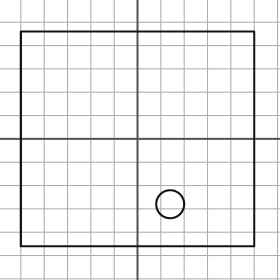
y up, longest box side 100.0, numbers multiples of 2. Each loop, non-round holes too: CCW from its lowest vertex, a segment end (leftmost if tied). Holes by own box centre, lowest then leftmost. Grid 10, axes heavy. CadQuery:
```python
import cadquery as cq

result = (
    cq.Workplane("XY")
    .moveTo(-50.0, -46.0)
    .lineTo(50.0, -46.0)
    .lineTo(50.0, 46.0)
    .lineTo(-50.0, 46.0)
    .close()
    .moveTo(14.0, -28.0)
    .circle(6.0)
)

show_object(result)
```